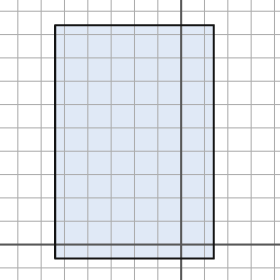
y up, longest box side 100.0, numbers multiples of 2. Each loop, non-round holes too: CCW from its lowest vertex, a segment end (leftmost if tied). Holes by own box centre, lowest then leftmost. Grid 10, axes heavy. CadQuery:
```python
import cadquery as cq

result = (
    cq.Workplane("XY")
    .moveTo(-54.0, -6.0)
    .lineTo(14.0, -6.0)
    .lineTo(14.0, 94.0)
    .lineTo(-54.0, 94.0)
    .close()
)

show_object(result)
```